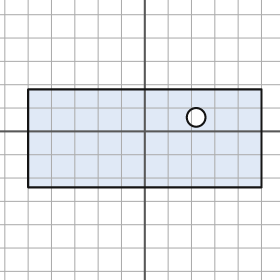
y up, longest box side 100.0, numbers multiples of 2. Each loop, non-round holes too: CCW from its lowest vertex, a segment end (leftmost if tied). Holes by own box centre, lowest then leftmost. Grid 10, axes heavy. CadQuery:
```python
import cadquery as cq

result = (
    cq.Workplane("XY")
    .moveTo(-50.0, -24.0)
    .lineTo(50.0, -24.0)
    .lineTo(50.0, 18.0)
    .lineTo(-50.0, 18.0)
    .close()
    .moveTo(22.0, 6.0)
    .circle(4.0)
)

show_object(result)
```